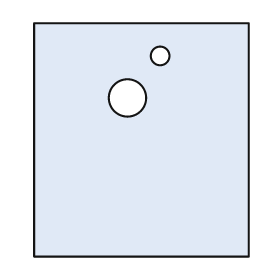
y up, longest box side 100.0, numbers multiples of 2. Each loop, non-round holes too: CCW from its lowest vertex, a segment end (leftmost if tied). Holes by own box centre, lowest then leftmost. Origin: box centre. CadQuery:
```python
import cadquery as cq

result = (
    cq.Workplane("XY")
    .moveTo(-46.0, -50.0)
    .lineTo(46.0, -50.0)
    .lineTo(46.0, 50.0)
    .lineTo(-46.0, 50.0)
    .close()
    .moveTo(-6.0, 18.0)
    .circle(8.0)
    .moveTo(8.0, 36.0)
    .circle(4.0)
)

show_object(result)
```